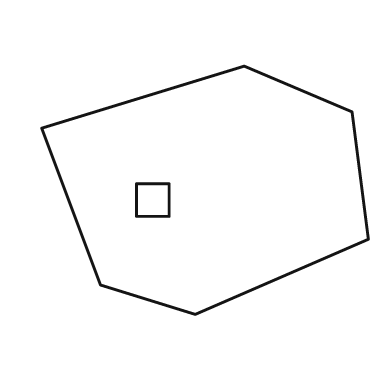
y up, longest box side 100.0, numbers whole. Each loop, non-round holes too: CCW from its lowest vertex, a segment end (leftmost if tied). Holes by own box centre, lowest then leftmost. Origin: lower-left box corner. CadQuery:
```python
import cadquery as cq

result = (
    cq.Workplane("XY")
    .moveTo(47.0, 0.0)
    .lineTo(100.0, 23.0)
    .lineTo(95.0, 62.0)
    .lineTo(62.0, 76.0)
    .lineTo(0.0, 57.0)
    .lineTo(18.0, 9.0)
    .close()
    .moveTo(29.0, 30.0)
    .lineTo(39.0, 30.0)
    .lineTo(39.0, 40.0)
    .lineTo(29.0, 40.0)
    .close()
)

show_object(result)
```